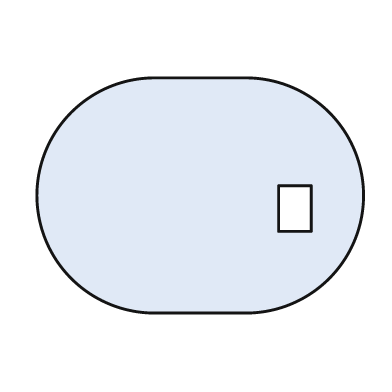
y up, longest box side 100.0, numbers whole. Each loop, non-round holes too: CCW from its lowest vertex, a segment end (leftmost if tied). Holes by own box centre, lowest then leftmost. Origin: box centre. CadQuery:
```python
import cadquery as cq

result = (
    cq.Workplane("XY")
    .moveTo(-14.0, -36.0)
    .lineTo(14.0, -36.0)
    .threePointArc((50.0, 0.0), (14.0, 36.0))
    .lineTo(-14.0, 36.0)
    .threePointArc((-50.0, 0.0), (-14.0, -36.0))
    .close()
    .moveTo(24.0, -11.0)
    .lineTo(34.0, -11.0)
    .lineTo(34.0, 3.0)
    .lineTo(24.0, 3.0)
    .close()
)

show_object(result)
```